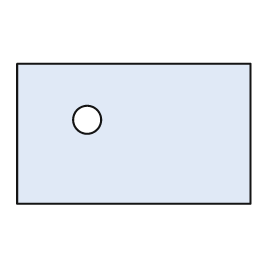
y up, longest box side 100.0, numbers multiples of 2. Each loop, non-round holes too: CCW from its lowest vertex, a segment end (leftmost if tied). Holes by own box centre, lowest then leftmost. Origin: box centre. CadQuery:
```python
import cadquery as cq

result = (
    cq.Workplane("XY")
    .moveTo(-50.0, -30.0)
    .lineTo(50.0, -30.0)
    .lineTo(50.0, 30.0)
    .lineTo(-50.0, 30.0)
    .close()
    .moveTo(-20.0, 6.0)
    .circle(6.0)
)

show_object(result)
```